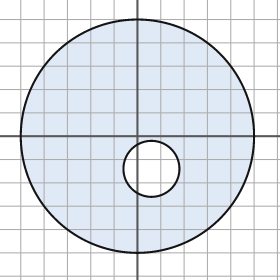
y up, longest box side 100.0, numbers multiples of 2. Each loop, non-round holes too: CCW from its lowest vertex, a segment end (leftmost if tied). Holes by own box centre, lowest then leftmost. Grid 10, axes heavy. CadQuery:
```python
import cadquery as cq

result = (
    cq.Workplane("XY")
    .moveTo(0.0, 0.0)
    .circle(50.0)
    .moveTo(6.0, -14.0)
    .circle(12.0)
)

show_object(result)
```